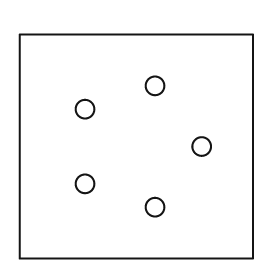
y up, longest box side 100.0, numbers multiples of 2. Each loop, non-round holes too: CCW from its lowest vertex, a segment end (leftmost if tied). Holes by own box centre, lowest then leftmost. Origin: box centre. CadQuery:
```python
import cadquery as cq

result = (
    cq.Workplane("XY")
    .moveTo(-50.0, -48.0)
    .lineTo(50.0, -48.0)
    .lineTo(50.0, 48.0)
    .lineTo(-50.0, 48.0)
    .close()
    .moveTo(8.0, -26.0)
    .circle(4.0)
    .moveTo(-22.0, -16.0)
    .circle(4.0)
    .moveTo(28.0, 0.0)
    .circle(4.0)
    .moveTo(-22.0, 16.0)
    .circle(4.0)
    .moveTo(8.0, 26.0)
    .circle(4.0)
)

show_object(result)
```